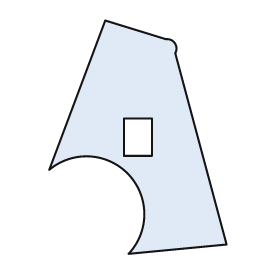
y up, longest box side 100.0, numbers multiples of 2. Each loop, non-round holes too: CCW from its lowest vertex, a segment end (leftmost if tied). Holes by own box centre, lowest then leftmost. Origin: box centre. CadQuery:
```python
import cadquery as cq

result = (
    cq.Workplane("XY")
    .moveTo(-4.0, -50.0)
    .lineTo(38.0, -46.0)
    .lineTo(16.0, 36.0)
    .threePointArc((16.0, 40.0), (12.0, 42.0))
    .lineTo(-14.0, 50.0)
    .lineTo(-38.0, -14.0)
    .threePointArc((-4.0, -16.0), (-4.0, -50.0))
    .close()
    .moveTo(-6.0, -8.0)
    .lineTo(6.0, -8.0)
    .lineTo(6.0, 8.0)
    .lineTo(-6.0, 8.0)
    .close()
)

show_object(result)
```